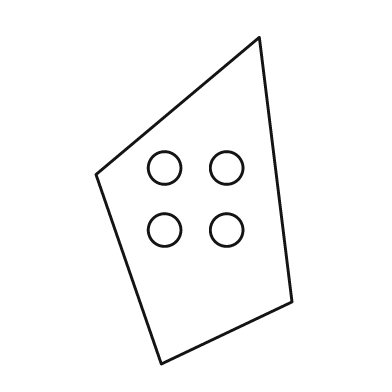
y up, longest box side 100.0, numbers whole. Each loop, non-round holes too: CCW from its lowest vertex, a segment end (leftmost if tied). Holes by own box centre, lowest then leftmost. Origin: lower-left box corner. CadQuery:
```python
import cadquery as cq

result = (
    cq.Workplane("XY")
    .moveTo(20.0, 0.0)
    .lineTo(60.0, 19.0)
    .lineTo(50.0, 100.0)
    .lineTo(0.0, 58.0)
    .close()
    .moveTo(21.0, 41.0)
    .circle(5.0)
    .moveTo(40.0, 41.0)
    .circle(5.0)
    .moveTo(21.0, 60.0)
    .circle(5.0)
    .moveTo(40.0, 60.0)
    .circle(5.0)
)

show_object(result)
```